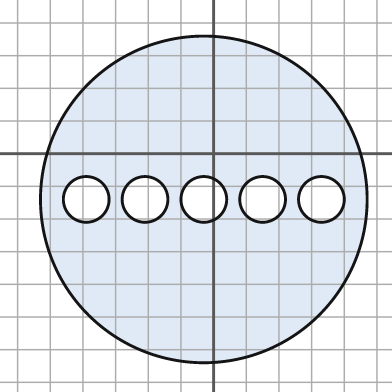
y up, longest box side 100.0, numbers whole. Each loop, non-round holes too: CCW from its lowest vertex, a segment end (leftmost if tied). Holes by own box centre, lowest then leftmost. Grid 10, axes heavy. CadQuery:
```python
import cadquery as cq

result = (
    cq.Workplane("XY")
    .moveTo(-3.0, -14.0)
    .circle(50.0)
    .moveTo(-39.0, -14.0)
    .circle(7.0)
    .moveTo(-21.0, -14.0)
    .circle(7.0)
    .moveTo(-3.0, -14.0)
    .circle(7.0)
    .moveTo(15.0, -14.0)
    .circle(7.0)
    .moveTo(33.0, -14.0)
    .circle(7.0)
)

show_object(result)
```